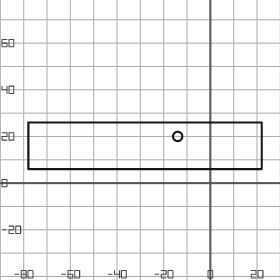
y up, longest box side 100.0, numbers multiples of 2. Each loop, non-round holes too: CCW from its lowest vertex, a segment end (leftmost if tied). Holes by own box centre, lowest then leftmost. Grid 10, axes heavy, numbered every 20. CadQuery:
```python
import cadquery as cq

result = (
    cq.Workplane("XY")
    .moveTo(-78.0, 6.0)
    .lineTo(22.0, 6.0)
    .lineTo(22.0, 26.0)
    .lineTo(-78.0, 26.0)
    .close()
    .moveTo(-14.0, 20.0)
    .circle(2.0)
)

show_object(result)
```